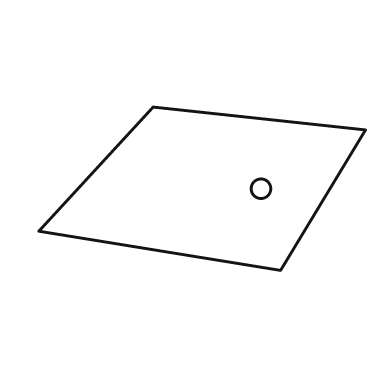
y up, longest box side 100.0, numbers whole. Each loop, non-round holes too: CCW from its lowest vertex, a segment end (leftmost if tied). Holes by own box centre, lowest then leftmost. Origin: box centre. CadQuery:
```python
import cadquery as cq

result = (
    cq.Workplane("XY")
    .moveTo(24.0, -25.0)
    .lineTo(50.0, 18.0)
    .lineTo(-15.0, 25.0)
    .lineTo(-50.0, -13.0)
    .close()
    .moveTo(18.0, 0.0)
    .circle(3.0)
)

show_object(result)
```